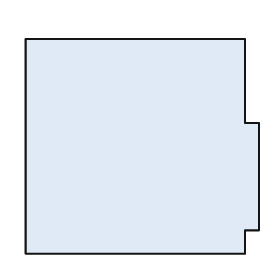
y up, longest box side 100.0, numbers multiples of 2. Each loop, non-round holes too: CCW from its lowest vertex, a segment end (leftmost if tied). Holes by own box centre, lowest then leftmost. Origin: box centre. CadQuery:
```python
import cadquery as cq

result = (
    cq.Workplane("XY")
    .moveTo(-50.0, -46.0)
    .lineTo(44.0, -46.0)
    .lineTo(44.0, -36.0)
    .lineTo(50.0, -36.0)
    .lineTo(50.0, 10.0)
    .lineTo(44.0, 10.0)
    .lineTo(44.0, 46.0)
    .lineTo(-50.0, 46.0)
    .close()
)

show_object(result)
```